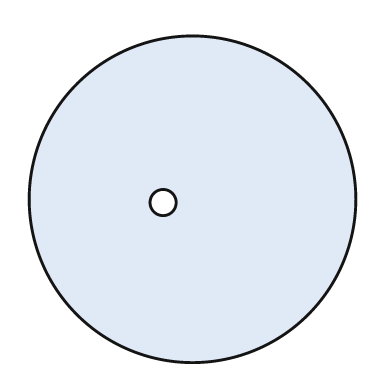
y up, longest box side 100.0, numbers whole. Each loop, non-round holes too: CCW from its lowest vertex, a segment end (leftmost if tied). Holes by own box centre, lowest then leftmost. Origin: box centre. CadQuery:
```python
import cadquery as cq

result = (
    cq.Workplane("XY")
    .moveTo(0.0, 0.0)
    .circle(50.0)
    .moveTo(-9.0, -1.0)
    .circle(4.0)
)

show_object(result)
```